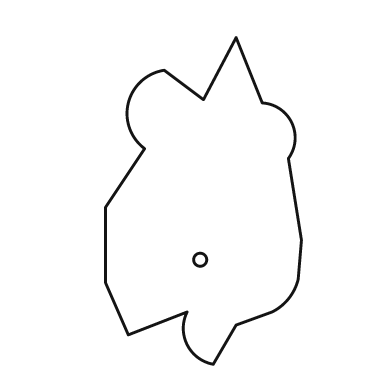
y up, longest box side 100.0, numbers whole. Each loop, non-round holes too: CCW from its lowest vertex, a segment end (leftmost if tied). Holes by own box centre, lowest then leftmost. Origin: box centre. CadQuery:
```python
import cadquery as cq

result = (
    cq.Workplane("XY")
    .moveTo(3.0, -50.0)
    .lineTo(10.0, -38.0)
    .lineTo(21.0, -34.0)
    .threePointArc((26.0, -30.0), (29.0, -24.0))
    .lineTo(30.0, -12.0)
    .lineTo(26.0, 13.0)
    .threePointArc((27.0, 24.0), (18.0, 30.0))
    .lineTo(10.0, 50.0)
    .lineTo(0.0, 31.0)
    .lineTo(-12.0, 40.0)
    .threePointArc((-23.0, 30.0), (-18.0, 16.0))
    .lineTo(-30.0, -2.0)
    .lineTo(-30.0, -25.0)
    .lineTo(-23.0, -41.0)
    .lineTo(-5.0, -34.0)
    .threePointArc((-5.0, -44.0), (3.0, -50.0))
    .close()
    .moveTo(-1.0, -18.0)
    .circle(2.0)
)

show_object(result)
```